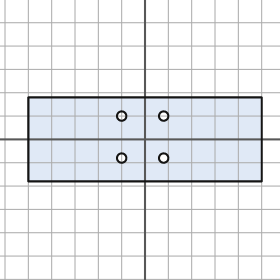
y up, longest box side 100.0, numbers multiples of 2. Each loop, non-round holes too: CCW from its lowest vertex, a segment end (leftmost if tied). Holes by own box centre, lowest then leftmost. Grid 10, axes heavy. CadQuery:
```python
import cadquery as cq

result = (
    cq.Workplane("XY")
    .moveTo(-50.0, -18.0)
    .lineTo(50.0, -18.0)
    .lineTo(50.0, 18.0)
    .lineTo(-50.0, 18.0)
    .close()
    .moveTo(-10.0, -8.0)
    .circle(2.0)
    .moveTo(8.0, -8.0)
    .circle(2.0)
    .moveTo(-10.0, 10.0)
    .circle(2.0)
    .moveTo(8.0, 10.0)
    .circle(2.0)
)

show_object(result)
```